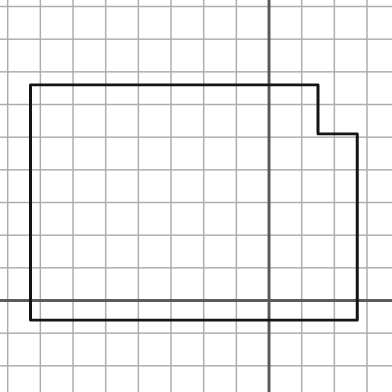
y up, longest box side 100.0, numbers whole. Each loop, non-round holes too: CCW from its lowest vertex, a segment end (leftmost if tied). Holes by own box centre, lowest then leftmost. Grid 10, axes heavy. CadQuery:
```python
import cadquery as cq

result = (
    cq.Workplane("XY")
    .moveTo(-73.0, -6.0)
    .lineTo(27.0, -6.0)
    .lineTo(27.0, 51.0)
    .lineTo(15.0, 51.0)
    .lineTo(15.0, 66.0)
    .lineTo(-73.0, 66.0)
    .close()
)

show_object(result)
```